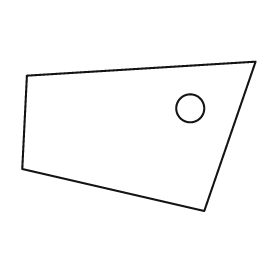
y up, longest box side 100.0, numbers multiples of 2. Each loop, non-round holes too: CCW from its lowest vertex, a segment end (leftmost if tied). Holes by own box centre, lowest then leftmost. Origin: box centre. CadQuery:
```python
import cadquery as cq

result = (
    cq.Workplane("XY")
    .moveTo(28.0, -32.0)
    .lineTo(50.0, 32.0)
    .lineTo(-48.0, 26.0)
    .lineTo(-50.0, -14.0)
    .close()
    .moveTo(22.0, 12.0)
    .circle(6.0)
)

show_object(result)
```